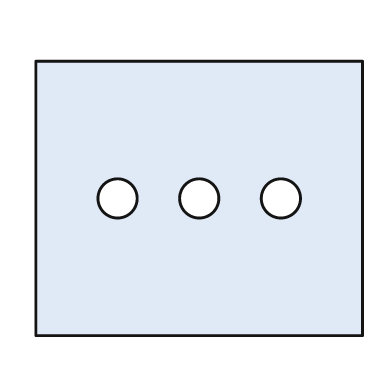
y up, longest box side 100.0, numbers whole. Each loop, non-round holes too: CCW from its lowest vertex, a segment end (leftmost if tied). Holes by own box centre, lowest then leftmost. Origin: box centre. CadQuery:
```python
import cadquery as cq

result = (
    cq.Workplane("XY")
    .moveTo(-50.0, -42.0)
    .lineTo(50.0, -42.0)
    .lineTo(50.0, 42.0)
    .lineTo(-50.0, 42.0)
    .close()
    .moveTo(-25.0, 0.0)
    .circle(6.0)
    .moveTo(0.0, 0.0)
    .circle(6.0)
    .moveTo(25.0, 0.0)
    .circle(6.0)
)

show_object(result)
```